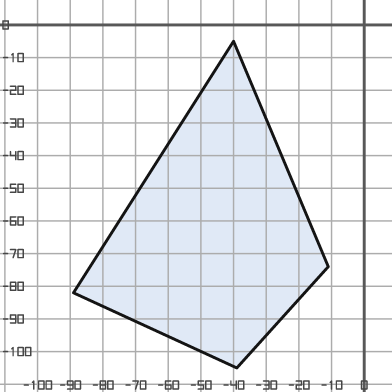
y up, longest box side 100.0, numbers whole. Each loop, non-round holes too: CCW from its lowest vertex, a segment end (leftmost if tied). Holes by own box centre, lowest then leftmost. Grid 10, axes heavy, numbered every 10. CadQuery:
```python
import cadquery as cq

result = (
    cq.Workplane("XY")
    .moveTo(-39.0, -105.0)
    .lineTo(-11.0, -74.0)
    .lineTo(-40.0, -5.0)
    .lineTo(-89.0, -82.0)
    .close()
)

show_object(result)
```